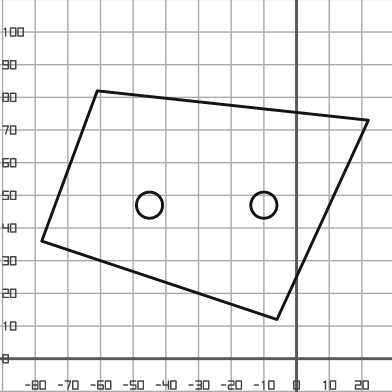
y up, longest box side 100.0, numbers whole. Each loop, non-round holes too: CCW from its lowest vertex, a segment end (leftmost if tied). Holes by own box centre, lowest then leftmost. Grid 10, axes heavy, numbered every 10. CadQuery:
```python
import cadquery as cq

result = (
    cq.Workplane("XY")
    .moveTo(-6.0, 12.0)
    .lineTo(22.0, 73.0)
    .lineTo(-61.0, 82.0)
    .lineTo(-78.0, 36.0)
    .close()
    .moveTo(-45.0, 47.0)
    .circle(4.0)
    .moveTo(-10.0, 47.0)
    .circle(4.0)
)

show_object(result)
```